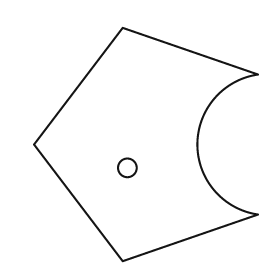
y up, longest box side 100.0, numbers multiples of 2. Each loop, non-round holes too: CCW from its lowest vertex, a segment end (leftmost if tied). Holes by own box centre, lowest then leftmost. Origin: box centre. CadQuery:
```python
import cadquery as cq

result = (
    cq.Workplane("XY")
    .moveTo(-10.0, -50.0)
    .lineTo(48.0, -30.0)
    .threePointArc((22.0, 0.0), (48.0, 30.0))
    .lineTo(-10.0, 50.0)
    .lineTo(-48.0, 0.0)
    .close()
    .moveTo(-8.0, -10.0)
    .circle(4.0)
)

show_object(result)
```